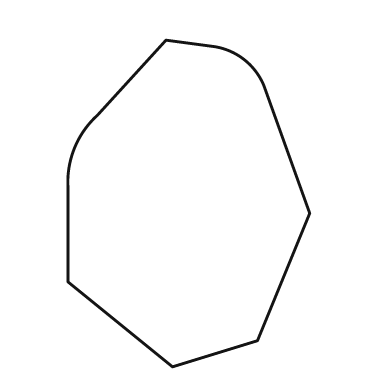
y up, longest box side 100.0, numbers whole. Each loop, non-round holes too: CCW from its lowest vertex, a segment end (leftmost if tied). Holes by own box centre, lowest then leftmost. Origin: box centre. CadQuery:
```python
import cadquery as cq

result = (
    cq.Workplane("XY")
    .moveTo(-5.0, -50.0)
    .lineTo(21.0, -42.0)
    .lineTo(37.0, -3.0)
    .lineTo(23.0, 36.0)
    .threePointArc((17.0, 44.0), (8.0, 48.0))
    .lineTo(-7.0, 50.0)
    .lineTo(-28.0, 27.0)
    .threePointArc((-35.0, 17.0), (-37.0, 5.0))
    .lineTo(-37.0, -24.0)
    .close()
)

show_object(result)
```